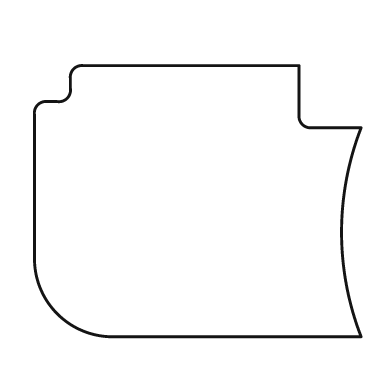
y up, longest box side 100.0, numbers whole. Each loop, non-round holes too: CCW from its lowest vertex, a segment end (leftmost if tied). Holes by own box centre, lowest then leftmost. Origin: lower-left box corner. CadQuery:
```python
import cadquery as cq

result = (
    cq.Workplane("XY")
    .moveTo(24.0, 0.0)
    .lineTo(100.0, 0.0)
    .threePointArc((94.0, 32.0), (100.0, 64.0))
    .lineTo(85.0, 64.0)
    .threePointArc((82.0, 65.0), (81.0, 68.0))
    .lineTo(81.0, 83.0)
    .lineTo(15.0, 83.0)
    .threePointArc((12.0, 82.0), (11.0, 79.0))
    .lineTo(11.0, 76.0)
    .threePointArc((10.0, 73.0), (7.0, 72.0))
    .lineTo(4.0, 72.0)
    .threePointArc((1.0, 71.0), (0.0, 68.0))
    .lineTo(0.0, 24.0)
    .threePointArc((7.0, 7.0), (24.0, 0.0))
    .close()
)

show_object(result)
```